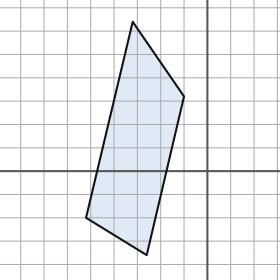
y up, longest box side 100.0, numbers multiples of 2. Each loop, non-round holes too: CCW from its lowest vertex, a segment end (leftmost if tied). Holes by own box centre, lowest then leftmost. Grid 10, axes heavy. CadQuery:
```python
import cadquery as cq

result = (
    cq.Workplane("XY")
    .moveTo(-26.0, -36.0)
    .lineTo(-10.0, 32.0)
    .lineTo(-32.0, 64.0)
    .lineTo(-52.0, -20.0)
    .close()
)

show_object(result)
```